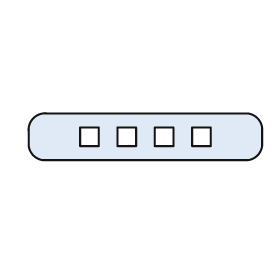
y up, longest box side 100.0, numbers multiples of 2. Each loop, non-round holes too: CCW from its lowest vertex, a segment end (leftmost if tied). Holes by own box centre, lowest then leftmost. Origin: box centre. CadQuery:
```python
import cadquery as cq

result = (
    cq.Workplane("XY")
    .moveTo(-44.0, -10.0)
    .lineTo(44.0, -10.0)
    .threePointArc((48.0, -8.0), (50.0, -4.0))
    .lineTo(50.0, 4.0)
    .threePointArc((48.0, 8.0), (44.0, 10.0))
    .lineTo(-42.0, 10.0)
    .threePointArc((-48.0, 8.0), (-50.0, 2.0))
    .lineTo(-50.0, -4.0)
    .threePointArc((-48.0, -8.0), (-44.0, -10.0))
    .close()
    .moveTo(-28.0, -4.0)
    .lineTo(-20.0, -4.0)
    .lineTo(-20.0, 4.0)
    .lineTo(-28.0, 4.0)
    .close()
    .moveTo(-12.0, -4.0)
    .lineTo(-4.0, -4.0)
    .lineTo(-4.0, 4.0)
    .lineTo(-12.0, 4.0)
    .close()
    .moveTo(4.0, -4.0)
    .lineTo(12.0, -4.0)
    .lineTo(12.0, 4.0)
    .lineTo(4.0, 4.0)
    .close()
    .moveTo(20.0, -4.0)
    .lineTo(28.0, -4.0)
    .lineTo(28.0, 4.0)
    .lineTo(20.0, 4.0)
    .close()
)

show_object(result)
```